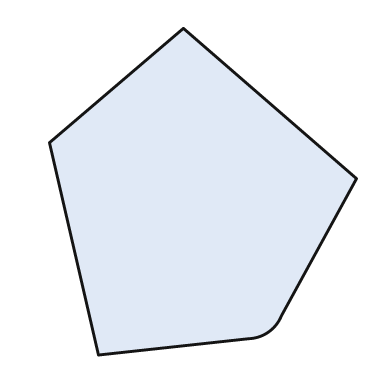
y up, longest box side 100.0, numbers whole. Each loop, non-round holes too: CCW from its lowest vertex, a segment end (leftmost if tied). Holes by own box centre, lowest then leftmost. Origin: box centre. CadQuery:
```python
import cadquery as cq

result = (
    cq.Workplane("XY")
    .moveTo(-32.0, -50.0)
    .lineTo(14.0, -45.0)
    .threePointArc((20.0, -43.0), (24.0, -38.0))
    .lineTo(47.0, 4.0)
    .lineTo(-6.0, 50.0)
    .lineTo(-47.0, 15.0)
    .close()
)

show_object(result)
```